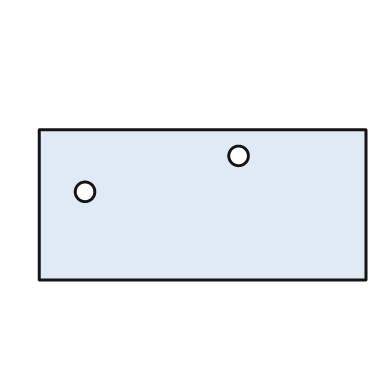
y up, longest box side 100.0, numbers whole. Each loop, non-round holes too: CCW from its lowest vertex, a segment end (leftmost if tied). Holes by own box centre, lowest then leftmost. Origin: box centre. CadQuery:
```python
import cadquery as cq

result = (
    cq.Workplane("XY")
    .moveTo(-50.0, -23.0)
    .lineTo(50.0, -23.0)
    .lineTo(50.0, 23.0)
    .lineTo(-50.0, 23.0)
    .close()
    .moveTo(-36.0, 4.0)
    .circle(3.0)
    .moveTo(11.0, 15.0)
    .circle(3.0)
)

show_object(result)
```